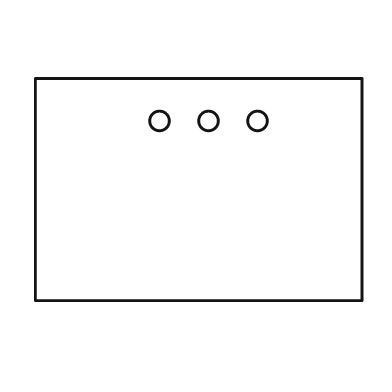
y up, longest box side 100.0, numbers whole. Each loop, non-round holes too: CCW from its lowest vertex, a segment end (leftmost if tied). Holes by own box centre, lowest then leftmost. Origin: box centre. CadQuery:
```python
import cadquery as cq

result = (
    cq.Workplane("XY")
    .moveTo(-50.0, -34.0)
    .lineTo(50.0, -34.0)
    .lineTo(50.0, 34.0)
    .lineTo(-50.0, 34.0)
    .close()
    .moveTo(-12.0, 21.0)
    .circle(3.0)
    .moveTo(3.0, 21.0)
    .circle(3.0)
    .moveTo(18.0, 21.0)
    .circle(3.0)
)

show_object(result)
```